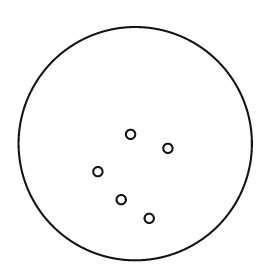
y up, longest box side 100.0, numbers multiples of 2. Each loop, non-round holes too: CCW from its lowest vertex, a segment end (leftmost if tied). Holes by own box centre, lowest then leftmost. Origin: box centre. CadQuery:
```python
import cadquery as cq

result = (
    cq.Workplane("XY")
    .moveTo(0.0, 0.0)
    .circle(50.0)
    .moveTo(6.0, -32.0)
    .circle(2.0)
    .moveTo(-6.0, -24.0)
    .circle(2.0)
    .moveTo(-16.0, -12.0)
    .circle(2.0)
    .moveTo(14.0, -2.0)
    .circle(2.0)
    .moveTo(-2.0, 4.0)
    .circle(2.0)
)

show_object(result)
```